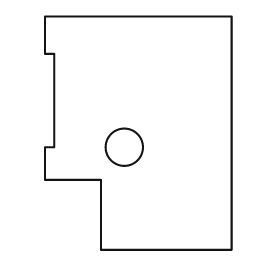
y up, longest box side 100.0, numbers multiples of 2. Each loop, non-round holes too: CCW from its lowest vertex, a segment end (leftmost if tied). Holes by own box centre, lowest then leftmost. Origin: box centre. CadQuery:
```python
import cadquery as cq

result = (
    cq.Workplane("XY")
    .moveTo(-16.0, -50.0)
    .lineTo(40.0, -50.0)
    .lineTo(40.0, 50.0)
    .lineTo(-40.0, 50.0)
    .lineTo(-40.0, 34.0)
    .lineTo(-36.0, 34.0)
    .lineTo(-36.0, -6.0)
    .lineTo(-40.0, -6.0)
    .lineTo(-40.0, -20.0)
    .lineTo(-16.0, -20.0)
    .close()
    .moveTo(-6.0, -6.0)
    .circle(8.0)
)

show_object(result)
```